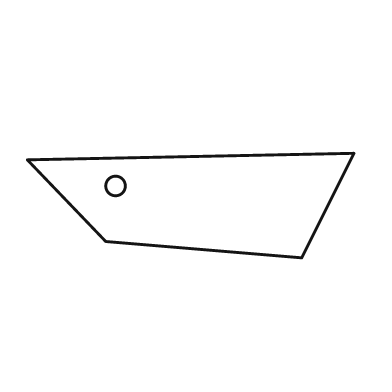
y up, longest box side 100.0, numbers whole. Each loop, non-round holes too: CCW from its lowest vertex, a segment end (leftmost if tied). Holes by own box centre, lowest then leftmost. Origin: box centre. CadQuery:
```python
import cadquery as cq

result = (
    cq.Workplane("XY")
    .moveTo(34.0, -16.0)
    .lineTo(50.0, 16.0)
    .lineTo(-50.0, 14.0)
    .lineTo(-26.0, -11.0)
    .close()
    .moveTo(-23.0, 6.0)
    .circle(3.0)
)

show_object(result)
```